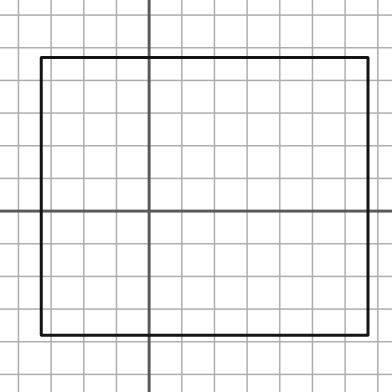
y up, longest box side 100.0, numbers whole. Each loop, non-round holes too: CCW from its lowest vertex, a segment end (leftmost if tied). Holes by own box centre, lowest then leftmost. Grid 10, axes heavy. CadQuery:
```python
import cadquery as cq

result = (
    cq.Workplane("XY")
    .moveTo(-33.0, -38.0)
    .lineTo(67.0, -38.0)
    .lineTo(67.0, 47.0)
    .lineTo(-33.0, 47.0)
    .close()
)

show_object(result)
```